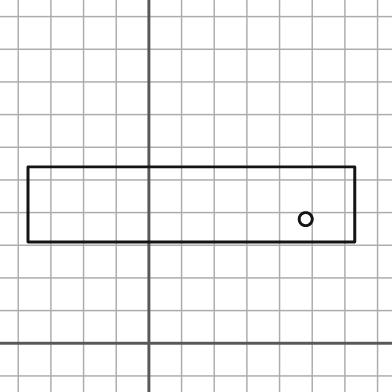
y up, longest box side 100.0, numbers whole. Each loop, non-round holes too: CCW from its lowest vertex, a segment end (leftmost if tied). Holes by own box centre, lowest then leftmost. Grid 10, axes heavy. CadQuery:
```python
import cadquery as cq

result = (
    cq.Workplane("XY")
    .moveTo(-37.0, 31.0)
    .lineTo(63.0, 31.0)
    .lineTo(63.0, 54.0)
    .lineTo(-37.0, 54.0)
    .close()
    .moveTo(48.0, 38.0)
    .circle(2.0)
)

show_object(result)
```